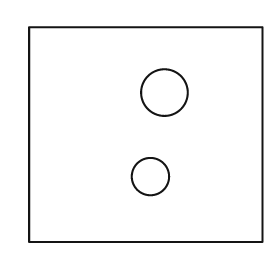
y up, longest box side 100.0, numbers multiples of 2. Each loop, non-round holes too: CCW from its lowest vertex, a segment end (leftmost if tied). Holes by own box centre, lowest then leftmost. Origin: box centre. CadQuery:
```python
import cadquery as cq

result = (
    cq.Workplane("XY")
    .moveTo(-50.0, -46.0)
    .lineTo(50.0, -46.0)
    .lineTo(50.0, 46.0)
    .lineTo(-50.0, 46.0)
    .close()
    .moveTo(2.0, -18.0)
    .circle(8.0)
    .moveTo(8.0, 18.0)
    .circle(10.0)
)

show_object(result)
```